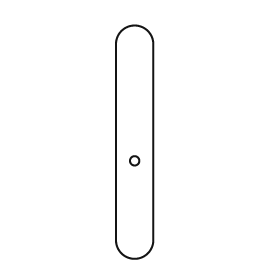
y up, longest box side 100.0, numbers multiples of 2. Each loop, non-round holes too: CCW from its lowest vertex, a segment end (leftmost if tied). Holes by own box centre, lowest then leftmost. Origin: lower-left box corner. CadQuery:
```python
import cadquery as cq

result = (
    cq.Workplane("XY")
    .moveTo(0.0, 8.0)
    .threePointArc((8.0, 0.0), (16.0, 8.0))
    .lineTo(16.0, 92.0)
    .threePointArc((8.0, 100.0), (0.0, 92.0))
    .close()
    .moveTo(8.0, 42.0)
    .circle(2.0)
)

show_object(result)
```